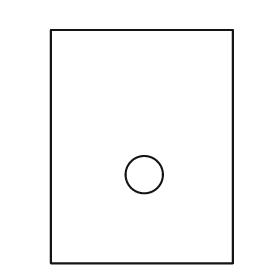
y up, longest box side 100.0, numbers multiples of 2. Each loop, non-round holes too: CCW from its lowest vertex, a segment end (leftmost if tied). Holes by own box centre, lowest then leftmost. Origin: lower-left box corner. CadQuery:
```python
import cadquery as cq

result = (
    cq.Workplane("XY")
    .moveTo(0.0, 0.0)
    .lineTo(78.0, 0.0)
    .lineTo(78.0, 100.0)
    .lineTo(0.0, 100.0)
    .close()
    .moveTo(40.0, 38.0)
    .circle(8.0)
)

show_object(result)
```